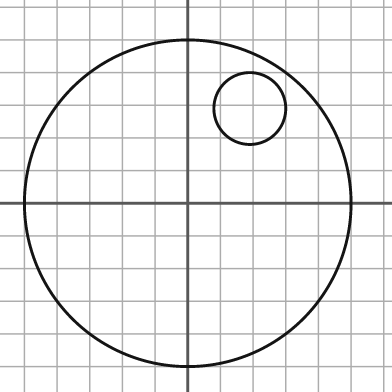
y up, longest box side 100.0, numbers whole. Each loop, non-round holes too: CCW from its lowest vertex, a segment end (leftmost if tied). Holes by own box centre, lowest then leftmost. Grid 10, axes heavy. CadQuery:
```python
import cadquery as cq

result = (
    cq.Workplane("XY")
    .moveTo(0.0, 0.0)
    .circle(50.0)
    .moveTo(19.0, 29.0)
    .circle(11.0)
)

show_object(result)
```